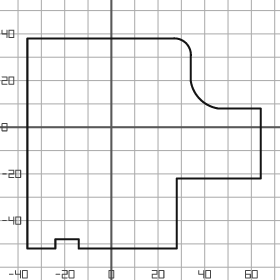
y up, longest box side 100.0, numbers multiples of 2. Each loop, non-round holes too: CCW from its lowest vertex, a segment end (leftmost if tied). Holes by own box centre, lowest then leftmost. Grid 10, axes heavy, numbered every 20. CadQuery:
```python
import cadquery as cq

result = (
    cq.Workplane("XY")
    .moveTo(-36.0, -52.0)
    .lineTo(-24.0, -52.0)
    .lineTo(-24.0, -48.0)
    .lineTo(-14.0, -48.0)
    .lineTo(-14.0, -52.0)
    .lineTo(28.0, -52.0)
    .lineTo(28.0, -22.0)
    .lineTo(64.0, -22.0)
    .lineTo(64.0, 8.0)
    .lineTo(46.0, 8.0)
    .threePointArc((38.0, 12.0), (34.0, 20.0))
    .lineTo(34.0, 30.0)
    .threePointArc((32.0, 36.0), (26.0, 38.0))
    .lineTo(-36.0, 38.0)
    .close()
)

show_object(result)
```